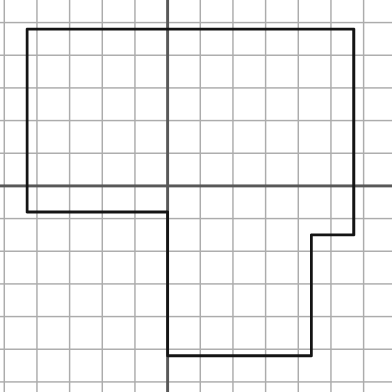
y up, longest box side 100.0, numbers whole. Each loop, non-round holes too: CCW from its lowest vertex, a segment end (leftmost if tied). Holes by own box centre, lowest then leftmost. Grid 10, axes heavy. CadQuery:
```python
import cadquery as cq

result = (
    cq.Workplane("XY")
    .moveTo(0.0, -52.0)
    .lineTo(44.0, -52.0)
    .lineTo(44.0, -15.0)
    .lineTo(57.0, -15.0)
    .lineTo(57.0, 48.0)
    .lineTo(-43.0, 48.0)
    .lineTo(-43.0, -8.0)
    .lineTo(0.0, -8.0)
    .close()
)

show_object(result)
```